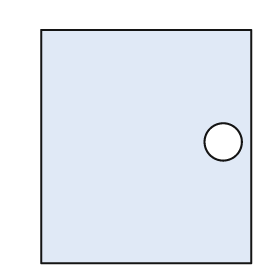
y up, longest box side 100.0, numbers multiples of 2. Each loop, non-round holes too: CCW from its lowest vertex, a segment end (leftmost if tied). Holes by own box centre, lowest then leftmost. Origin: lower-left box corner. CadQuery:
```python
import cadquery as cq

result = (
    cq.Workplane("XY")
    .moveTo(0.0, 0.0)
    .lineTo(90.0, 0.0)
    .lineTo(90.0, 100.0)
    .lineTo(0.0, 100.0)
    .close()
    .moveTo(78.0, 52.0)
    .circle(8.0)
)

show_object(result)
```